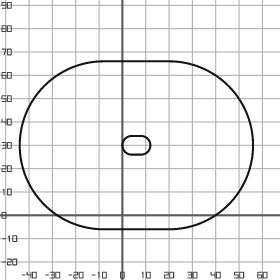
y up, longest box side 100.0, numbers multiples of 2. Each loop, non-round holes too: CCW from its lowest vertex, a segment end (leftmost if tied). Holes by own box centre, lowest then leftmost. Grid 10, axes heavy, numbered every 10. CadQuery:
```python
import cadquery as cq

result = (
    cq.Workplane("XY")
    .moveTo(-8.0, -6.0)
    .lineTo(20.0, -6.0)
    .threePointArc((56.0, 30.0), (20.0, 66.0))
    .lineTo(-8.0, 66.0)
    .threePointArc((-44.0, 30.0), (-8.0, -6.0))
    .close()
    .moveTo(4.0, 26.0)
    .lineTo(8.0, 26.0)
    .threePointArc((12.0, 30.0), (8.0, 34.0))
    .lineTo(4.0, 34.0)
    .threePointArc((0.0, 30.0), (4.0, 26.0))
    .close()
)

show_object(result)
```